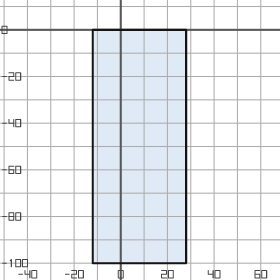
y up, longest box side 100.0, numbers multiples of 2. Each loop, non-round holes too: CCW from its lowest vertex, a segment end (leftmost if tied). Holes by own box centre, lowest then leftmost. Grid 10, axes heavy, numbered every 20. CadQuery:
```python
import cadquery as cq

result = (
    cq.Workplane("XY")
    .moveTo(-12.0, -100.0)
    .lineTo(28.0, -100.0)
    .lineTo(28.0, 0.0)
    .lineTo(-12.0, 0.0)
    .close()
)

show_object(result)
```